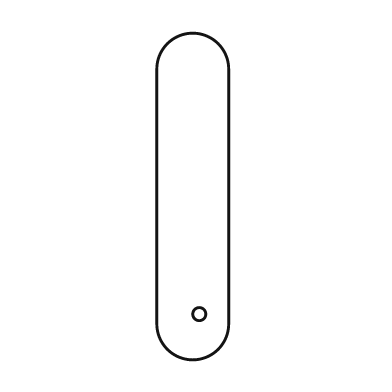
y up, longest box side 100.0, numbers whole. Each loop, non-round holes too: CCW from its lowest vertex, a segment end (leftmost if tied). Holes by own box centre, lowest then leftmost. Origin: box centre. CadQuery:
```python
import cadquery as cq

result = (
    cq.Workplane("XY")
    .moveTo(-11.0, -39.0)
    .threePointArc((0.0, -50.0), (11.0, -39.0))
    .lineTo(11.0, 39.0)
    .threePointArc((0.0, 50.0), (-11.0, 39.0))
    .close()
    .moveTo(2.0, -36.0)
    .circle(2.0)
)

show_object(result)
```